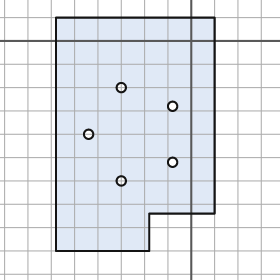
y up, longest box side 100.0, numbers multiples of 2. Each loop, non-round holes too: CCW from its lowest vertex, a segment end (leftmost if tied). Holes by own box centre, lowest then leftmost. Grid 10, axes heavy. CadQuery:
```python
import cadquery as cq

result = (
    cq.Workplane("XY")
    .moveTo(-58.0, -90.0)
    .lineTo(-18.0, -90.0)
    .lineTo(-18.0, -74.0)
    .lineTo(10.0, -74.0)
    .lineTo(10.0, 10.0)
    .lineTo(-58.0, 10.0)
    .close()
    .moveTo(-30.0, -60.0)
    .circle(2.0)
    .moveTo(-8.0, -52.0)
    .circle(2.0)
    .moveTo(-44.0, -40.0)
    .circle(2.0)
    .moveTo(-8.0, -28.0)
    .circle(2.0)
    .moveTo(-30.0, -20.0)
    .circle(2.0)
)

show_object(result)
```